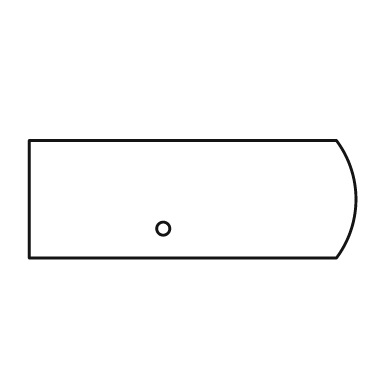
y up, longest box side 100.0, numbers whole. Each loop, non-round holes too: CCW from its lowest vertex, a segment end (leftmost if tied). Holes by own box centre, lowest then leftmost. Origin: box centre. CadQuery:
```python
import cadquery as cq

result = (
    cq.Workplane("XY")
    .moveTo(-50.0, -18.0)
    .lineTo(44.0, -18.0)
    .threePointArc((50.0, 0.0), (44.0, 18.0))
    .lineTo(-50.0, 18.0)
    .close()
    .moveTo(-9.0, -9.0)
    .circle(2.0)
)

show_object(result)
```